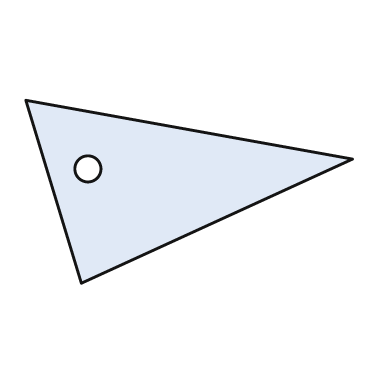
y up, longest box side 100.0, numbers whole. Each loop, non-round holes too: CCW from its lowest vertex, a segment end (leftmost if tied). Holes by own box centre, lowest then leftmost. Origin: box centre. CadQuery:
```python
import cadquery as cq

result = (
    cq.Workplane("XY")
    .moveTo(-33.0, -28.0)
    .lineTo(50.0, 10.0)
    .lineTo(-50.0, 28.0)
    .close()
    .moveTo(-31.0, 7.0)
    .circle(4.0)
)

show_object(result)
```